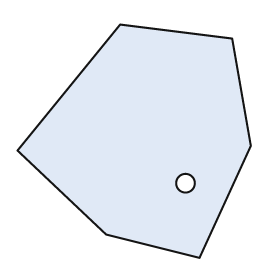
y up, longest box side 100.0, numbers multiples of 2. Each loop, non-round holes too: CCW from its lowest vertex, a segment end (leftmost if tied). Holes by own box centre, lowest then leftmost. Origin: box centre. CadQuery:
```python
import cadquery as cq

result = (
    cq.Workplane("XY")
    .moveTo(28.0, -50.0)
    .lineTo(50.0, -2.0)
    .lineTo(42.0, 44.0)
    .lineTo(-6.0, 50.0)
    .lineTo(-50.0, -4.0)
    .lineTo(-12.0, -40.0)
    .close()
    .moveTo(22.0, -18.0)
    .circle(4.0)
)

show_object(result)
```